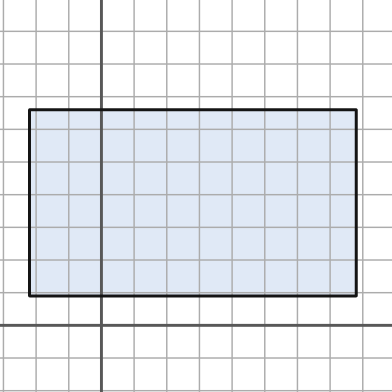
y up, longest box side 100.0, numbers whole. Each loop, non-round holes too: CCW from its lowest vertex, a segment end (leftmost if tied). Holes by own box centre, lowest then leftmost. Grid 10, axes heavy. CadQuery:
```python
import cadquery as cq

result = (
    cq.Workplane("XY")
    .moveTo(-22.0, 9.0)
    .lineTo(78.0, 9.0)
    .lineTo(78.0, 66.0)
    .lineTo(-22.0, 66.0)
    .close()
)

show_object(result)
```